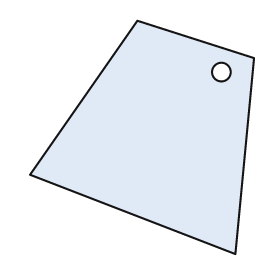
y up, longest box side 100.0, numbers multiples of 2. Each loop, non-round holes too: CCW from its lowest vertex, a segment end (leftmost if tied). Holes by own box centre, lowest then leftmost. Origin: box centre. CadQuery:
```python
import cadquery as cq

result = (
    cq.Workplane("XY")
    .moveTo(40.0, -50.0)
    .lineTo(48.0, 34.0)
    .lineTo(-2.0, 50.0)
    .lineTo(-48.0, -16.0)
    .close()
    .moveTo(34.0, 28.0)
    .circle(4.0)
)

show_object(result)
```